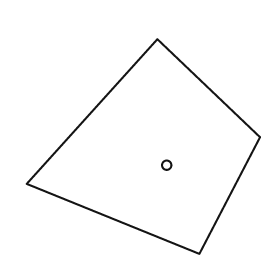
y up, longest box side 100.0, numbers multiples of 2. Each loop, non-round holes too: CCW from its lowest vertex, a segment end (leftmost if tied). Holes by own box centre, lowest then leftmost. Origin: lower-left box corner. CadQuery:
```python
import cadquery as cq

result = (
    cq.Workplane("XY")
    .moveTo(74.0, 0.0)
    .lineTo(100.0, 50.0)
    .lineTo(56.0, 92.0)
    .lineTo(0.0, 30.0)
    .close()
    .moveTo(60.0, 38.0)
    .circle(2.0)
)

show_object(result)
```